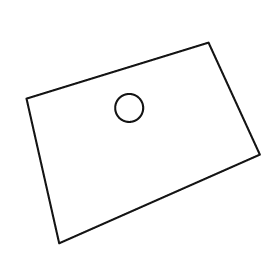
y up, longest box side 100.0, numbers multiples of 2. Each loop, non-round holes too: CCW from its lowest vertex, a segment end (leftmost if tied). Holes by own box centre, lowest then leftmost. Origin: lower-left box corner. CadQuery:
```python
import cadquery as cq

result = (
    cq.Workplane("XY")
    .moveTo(14.0, 0.0)
    .lineTo(100.0, 38.0)
    .lineTo(78.0, 86.0)
    .lineTo(0.0, 62.0)
    .close()
    .moveTo(44.0, 58.0)
    .circle(6.0)
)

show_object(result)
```